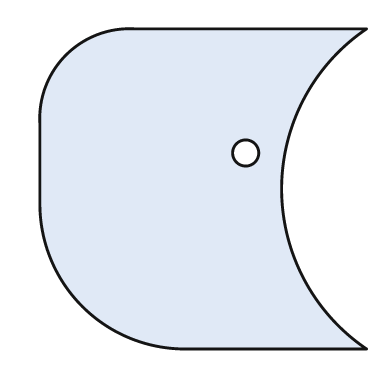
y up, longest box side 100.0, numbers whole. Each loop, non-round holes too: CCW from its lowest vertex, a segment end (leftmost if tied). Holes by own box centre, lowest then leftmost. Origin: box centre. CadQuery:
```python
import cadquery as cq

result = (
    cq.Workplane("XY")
    .moveTo(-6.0, -49.0)
    .lineTo(50.0, -49.0)
    .threePointArc((24.0, 0.0), (50.0, 49.0))
    .lineTo(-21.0, 49.0)
    .threePointArc((-42.0, 41.0), (-50.0, 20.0))
    .lineTo(-50.0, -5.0)
    .threePointArc((-37.0, -36.0), (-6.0, -49.0))
    .close()
    .moveTo(13.0, 11.0)
    .circle(4.0)
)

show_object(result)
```